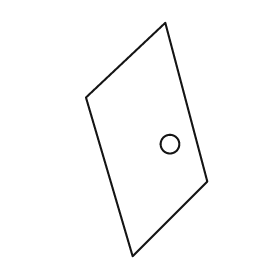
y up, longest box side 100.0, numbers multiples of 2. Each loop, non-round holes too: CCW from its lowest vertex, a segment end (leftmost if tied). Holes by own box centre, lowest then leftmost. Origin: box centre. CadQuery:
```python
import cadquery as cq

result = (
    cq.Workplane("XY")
    .moveTo(-6.0, -50.0)
    .lineTo(26.0, -18.0)
    .lineTo(8.0, 50.0)
    .lineTo(-26.0, 18.0)
    .close()
    .moveTo(10.0, -2.0)
    .circle(4.0)
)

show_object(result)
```